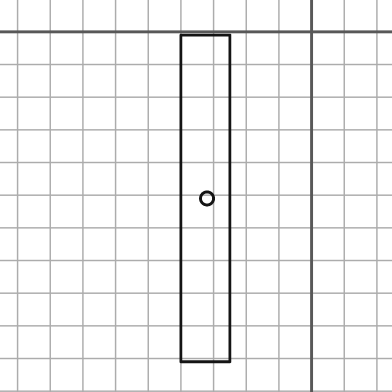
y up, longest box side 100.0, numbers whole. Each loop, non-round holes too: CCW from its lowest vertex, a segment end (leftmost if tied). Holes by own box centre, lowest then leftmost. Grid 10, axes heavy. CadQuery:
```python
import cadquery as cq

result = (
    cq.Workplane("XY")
    .moveTo(-40.0, -101.0)
    .lineTo(-25.0, -101.0)
    .lineTo(-25.0, -1.0)
    .lineTo(-40.0, -1.0)
    .close()
    .moveTo(-32.0, -51.0)
    .circle(2.0)
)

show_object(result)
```